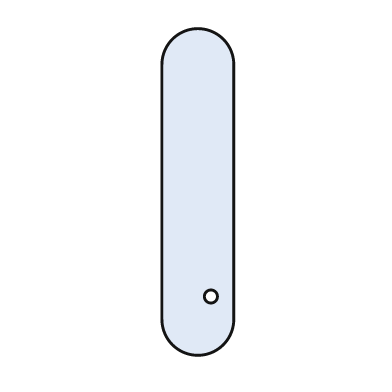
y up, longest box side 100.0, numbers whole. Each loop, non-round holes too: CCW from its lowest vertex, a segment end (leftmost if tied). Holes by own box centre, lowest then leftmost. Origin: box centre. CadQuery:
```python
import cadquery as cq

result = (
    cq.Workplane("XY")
    .moveTo(-11.0, -39.0)
    .threePointArc((0.0, -50.0), (11.0, -39.0))
    .lineTo(11.0, 39.0)
    .threePointArc((0.0, 50.0), (-11.0, 39.0))
    .close()
    .moveTo(4.0, -32.0)
    .circle(2.0)
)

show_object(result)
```